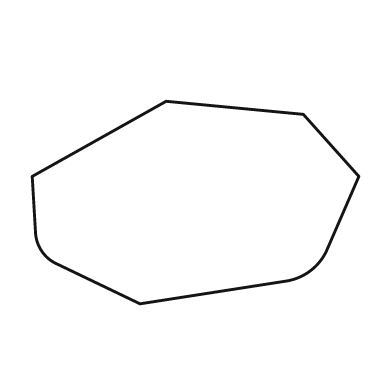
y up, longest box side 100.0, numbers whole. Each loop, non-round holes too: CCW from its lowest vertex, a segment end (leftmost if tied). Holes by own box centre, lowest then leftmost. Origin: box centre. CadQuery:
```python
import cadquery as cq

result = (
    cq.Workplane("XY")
    .moveTo(-17.0, -31.0)
    .lineTo(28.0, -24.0)
    .threePointArc((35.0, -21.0), (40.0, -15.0))
    .lineTo(50.0, 8.0)
    .lineTo(33.0, 27.0)
    .lineTo(-9.0, 31.0)
    .lineTo(-50.0, 8.0)
    .lineTo(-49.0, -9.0)
    .threePointArc((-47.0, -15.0), (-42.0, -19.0))
    .close()
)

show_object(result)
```